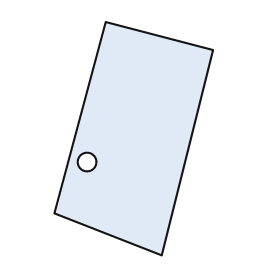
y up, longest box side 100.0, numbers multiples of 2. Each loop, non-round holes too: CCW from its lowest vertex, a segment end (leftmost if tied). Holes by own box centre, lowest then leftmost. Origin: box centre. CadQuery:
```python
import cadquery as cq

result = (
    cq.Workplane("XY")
    .moveTo(12.0, -50.0)
    .lineTo(34.0, 38.0)
    .lineTo(-12.0, 50.0)
    .lineTo(-34.0, -32.0)
    .close()
    .moveTo(-20.0, -10.0)
    .circle(4.0)
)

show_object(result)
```